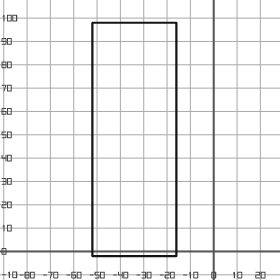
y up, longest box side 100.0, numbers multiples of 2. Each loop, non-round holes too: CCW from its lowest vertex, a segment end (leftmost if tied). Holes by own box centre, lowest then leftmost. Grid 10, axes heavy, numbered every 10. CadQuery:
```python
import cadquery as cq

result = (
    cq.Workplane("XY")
    .moveTo(-52.0, -2.0)
    .lineTo(-16.0, -2.0)
    .lineTo(-16.0, 98.0)
    .lineTo(-52.0, 98.0)
    .close()
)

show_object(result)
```